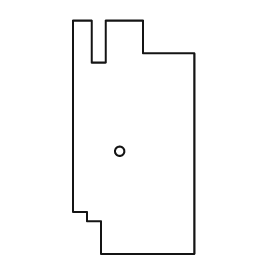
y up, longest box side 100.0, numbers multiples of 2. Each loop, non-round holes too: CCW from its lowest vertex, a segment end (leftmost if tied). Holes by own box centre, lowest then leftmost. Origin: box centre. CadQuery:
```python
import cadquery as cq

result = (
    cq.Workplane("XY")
    .moveTo(-14.0, -50.0)
    .lineTo(26.0, -50.0)
    .lineTo(26.0, 36.0)
    .lineTo(4.0, 36.0)
    .lineTo(4.0, 50.0)
    .lineTo(-12.0, 50.0)
    .lineTo(-12.0, 32.0)
    .lineTo(-18.0, 32.0)
    .lineTo(-18.0, 50.0)
    .lineTo(-26.0, 50.0)
    .lineTo(-26.0, -32.0)
    .lineTo(-20.0, -32.0)
    .lineTo(-20.0, -36.0)
    .lineTo(-14.0, -36.0)
    .close()
    .moveTo(-6.0, -6.0)
    .circle(2.0)
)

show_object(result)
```